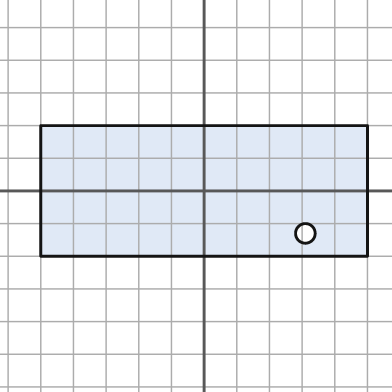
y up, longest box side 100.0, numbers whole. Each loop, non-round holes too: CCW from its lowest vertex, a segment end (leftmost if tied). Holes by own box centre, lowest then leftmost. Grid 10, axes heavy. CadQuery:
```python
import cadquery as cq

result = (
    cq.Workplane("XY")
    .moveTo(-50.0, -20.0)
    .lineTo(50.0, -20.0)
    .lineTo(50.0, 20.0)
    .lineTo(-50.0, 20.0)
    .close()
    .moveTo(31.0, -13.0)
    .circle(3.0)
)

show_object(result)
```